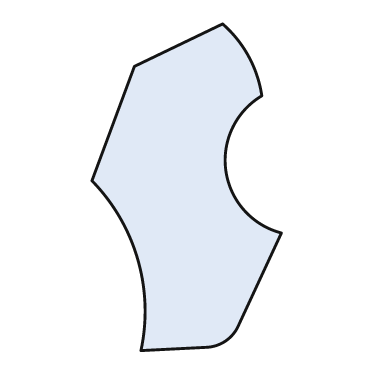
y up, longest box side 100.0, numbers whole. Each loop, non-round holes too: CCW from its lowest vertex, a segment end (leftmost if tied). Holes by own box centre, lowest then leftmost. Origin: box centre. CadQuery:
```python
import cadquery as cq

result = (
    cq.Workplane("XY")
    .moveTo(-14.0, -50.0)
    .lineTo(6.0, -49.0)
    .threePointArc((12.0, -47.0), (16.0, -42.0))
    .lineTo(29.0, -14.0)
    .threePointArc((12.0, 5.0), (23.0, 28.0))
    .threePointArc((19.0, 40.0), (11.0, 50.0))
    .lineTo(-16.0, 37.0)
    .lineTo(-29.0, 2.0)
    .threePointArc((-15.0, -22.0), (-14.0, -50.0))
    .close()
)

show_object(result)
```